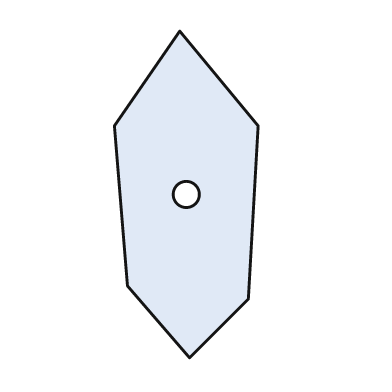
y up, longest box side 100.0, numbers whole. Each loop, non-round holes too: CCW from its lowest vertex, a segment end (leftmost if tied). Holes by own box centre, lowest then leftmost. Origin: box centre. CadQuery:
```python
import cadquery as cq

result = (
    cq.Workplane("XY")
    .moveTo(1.0, -50.0)
    .lineTo(19.0, -32.0)
    .lineTo(22.0, 21.0)
    .lineTo(-2.0, 50.0)
    .lineTo(-22.0, 21.0)
    .lineTo(-18.0, -28.0)
    .close()
    .moveTo(0.0, 0.0)
    .circle(4.0)
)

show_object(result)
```